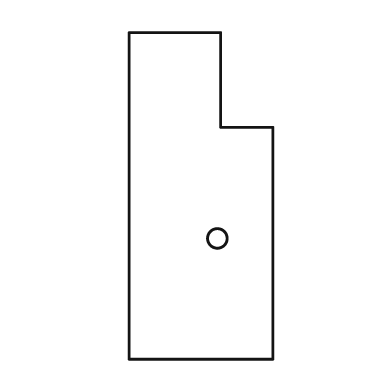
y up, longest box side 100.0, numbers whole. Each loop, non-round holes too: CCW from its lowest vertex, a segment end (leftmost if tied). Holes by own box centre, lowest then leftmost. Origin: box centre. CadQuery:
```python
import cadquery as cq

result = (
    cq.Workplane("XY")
    .moveTo(-22.0, -50.0)
    .lineTo(22.0, -50.0)
    .lineTo(22.0, 21.0)
    .lineTo(6.0, 21.0)
    .lineTo(6.0, 50.0)
    .lineTo(-22.0, 50.0)
    .close()
    .moveTo(5.0, -13.0)
    .circle(3.0)
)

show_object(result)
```